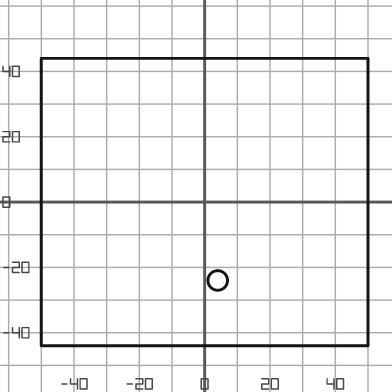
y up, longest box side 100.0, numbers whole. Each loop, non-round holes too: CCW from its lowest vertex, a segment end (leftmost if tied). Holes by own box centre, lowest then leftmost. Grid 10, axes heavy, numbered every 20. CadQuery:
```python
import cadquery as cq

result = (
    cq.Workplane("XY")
    .moveTo(-50.0, -44.0)
    .lineTo(50.0, -44.0)
    .lineTo(50.0, 44.0)
    .lineTo(-50.0, 44.0)
    .close()
    .moveTo(4.0, -24.0)
    .circle(3.0)
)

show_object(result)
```